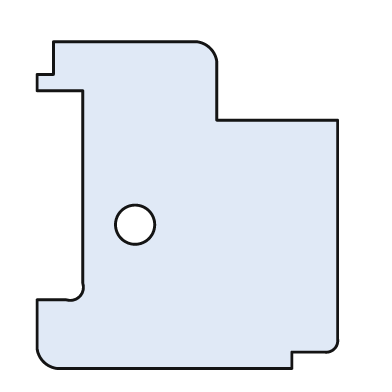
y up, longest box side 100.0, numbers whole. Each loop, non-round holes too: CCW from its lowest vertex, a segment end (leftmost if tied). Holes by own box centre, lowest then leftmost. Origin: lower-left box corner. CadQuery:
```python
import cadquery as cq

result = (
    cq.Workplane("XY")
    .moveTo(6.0, 0.0)
    .lineTo(78.0, 0.0)
    .lineTo(78.0, 5.0)
    .lineTo(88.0, 5.0)
    .threePointArc((91.0, 6.0), (92.0, 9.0))
    .lineTo(92.0, 76.0)
    .lineTo(55.0, 76.0)
    .lineTo(55.0, 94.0)
    .threePointArc((53.0, 98.0), (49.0, 100.0))
    .lineTo(5.0, 100.0)
    .lineTo(5.0, 90.0)
    .lineTo(0.0, 90.0)
    .lineTo(0.0, 85.0)
    .lineTo(14.0, 85.0)
    .lineTo(14.0, 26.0)
    .threePointArc((13.0, 22.0), (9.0, 21.0))
    .lineTo(0.0, 21.0)
    .lineTo(0.0, 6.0)
    .threePointArc((2.0, 2.0), (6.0, 0.0))
    .close()
    .moveTo(30.0, 44.0)
    .circle(6.0)
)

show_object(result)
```